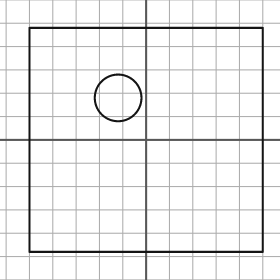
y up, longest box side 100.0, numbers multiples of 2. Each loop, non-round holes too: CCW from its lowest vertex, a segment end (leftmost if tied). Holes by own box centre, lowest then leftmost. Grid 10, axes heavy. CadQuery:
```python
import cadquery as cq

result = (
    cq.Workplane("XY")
    .moveTo(-50.0, -48.0)
    .lineTo(50.0, -48.0)
    .lineTo(50.0, 48.0)
    .lineTo(-50.0, 48.0)
    .close()
    .moveTo(-12.0, 18.0)
    .circle(10.0)
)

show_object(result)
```